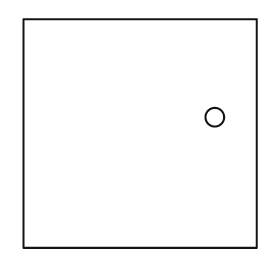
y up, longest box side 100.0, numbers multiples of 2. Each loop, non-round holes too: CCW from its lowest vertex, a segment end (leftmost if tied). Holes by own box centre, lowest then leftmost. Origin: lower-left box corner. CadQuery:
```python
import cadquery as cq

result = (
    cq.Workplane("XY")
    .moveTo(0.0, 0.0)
    .lineTo(100.0, 0.0)
    .lineTo(100.0, 98.0)
    .lineTo(0.0, 98.0)
    .close()
    .moveTo(82.0, 56.0)
    .circle(4.0)
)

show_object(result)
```